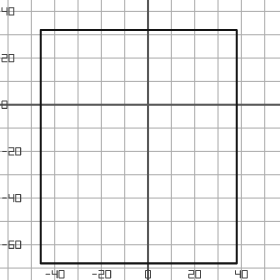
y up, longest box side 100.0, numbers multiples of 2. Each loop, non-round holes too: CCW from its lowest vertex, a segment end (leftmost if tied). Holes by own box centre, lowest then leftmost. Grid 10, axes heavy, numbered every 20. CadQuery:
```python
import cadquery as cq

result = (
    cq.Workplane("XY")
    .moveTo(-46.0, -68.0)
    .lineTo(38.0, -68.0)
    .lineTo(38.0, 32.0)
    .lineTo(-46.0, 32.0)
    .close()
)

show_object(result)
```